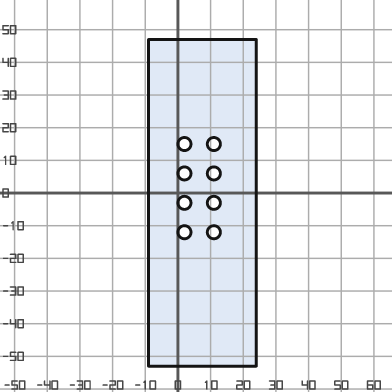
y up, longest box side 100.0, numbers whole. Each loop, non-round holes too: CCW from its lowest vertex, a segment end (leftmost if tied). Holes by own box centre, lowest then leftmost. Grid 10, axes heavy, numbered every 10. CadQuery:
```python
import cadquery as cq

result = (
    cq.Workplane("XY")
    .moveTo(-9.0, -53.0)
    .lineTo(24.0, -53.0)
    .lineTo(24.0, 47.0)
    .lineTo(-9.0, 47.0)
    .close()
    .moveTo(2.0, -12.0)
    .circle(2.0)
    .moveTo(11.0, -12.0)
    .circle(2.0)
    .moveTo(2.0, -3.0)
    .circle(2.0)
    .moveTo(11.0, -3.0)
    .circle(2.0)
    .moveTo(2.0, 6.0)
    .circle(2.0)
    .moveTo(11.0, 6.0)
    .circle(2.0)
    .moveTo(2.0, 15.0)
    .circle(2.0)
    .moveTo(11.0, 15.0)
    .circle(2.0)
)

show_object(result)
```